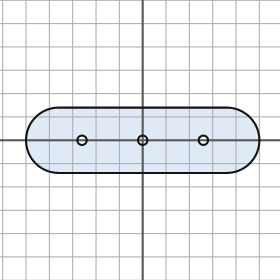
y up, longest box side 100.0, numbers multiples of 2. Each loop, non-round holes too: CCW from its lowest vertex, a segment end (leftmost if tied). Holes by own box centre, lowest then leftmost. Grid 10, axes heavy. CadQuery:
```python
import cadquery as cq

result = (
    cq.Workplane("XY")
    .moveTo(-36.0, -14.0)
    .lineTo(36.0, -14.0)
    .threePointArc((50.0, 0.0), (36.0, 14.0))
    .lineTo(-36.0, 14.0)
    .threePointArc((-50.0, 0.0), (-36.0, -14.0))
    .close()
    .moveTo(-26.0, 0.0)
    .circle(2.0)
    .moveTo(0.0, 0.0)
    .circle(2.0)
    .moveTo(26.0, 0.0)
    .circle(2.0)
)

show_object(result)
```